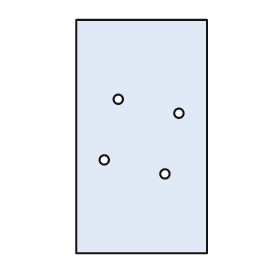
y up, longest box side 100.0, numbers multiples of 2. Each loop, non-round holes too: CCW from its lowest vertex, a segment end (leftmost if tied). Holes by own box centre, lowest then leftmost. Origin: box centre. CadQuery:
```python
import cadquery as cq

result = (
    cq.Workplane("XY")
    .moveTo(-28.0, -50.0)
    .lineTo(28.0, -50.0)
    .lineTo(28.0, 50.0)
    .lineTo(-28.0, 50.0)
    .close()
    .moveTo(10.0, -16.0)
    .circle(2.0)
    .moveTo(-16.0, -10.0)
    .circle(2.0)
    .moveTo(16.0, 10.0)
    .circle(2.0)
    .moveTo(-10.0, 16.0)
    .circle(2.0)
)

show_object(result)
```